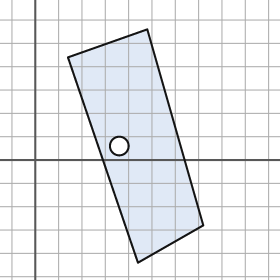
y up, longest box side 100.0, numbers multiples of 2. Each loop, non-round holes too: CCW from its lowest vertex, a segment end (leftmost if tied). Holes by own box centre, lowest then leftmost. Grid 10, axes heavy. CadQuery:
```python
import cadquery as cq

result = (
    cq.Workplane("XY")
    .moveTo(44.0, -44.0)
    .lineTo(72.0, -28.0)
    .lineTo(48.0, 56.0)
    .lineTo(14.0, 44.0)
    .close()
    .moveTo(36.0, 6.0)
    .circle(4.0)
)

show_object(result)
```